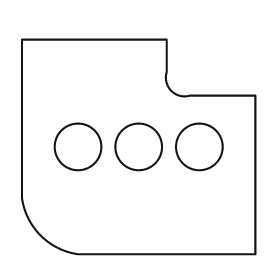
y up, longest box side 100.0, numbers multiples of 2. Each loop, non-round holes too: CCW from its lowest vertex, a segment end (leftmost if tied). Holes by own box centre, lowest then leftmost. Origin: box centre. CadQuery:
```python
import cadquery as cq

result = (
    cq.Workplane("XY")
    .moveTo(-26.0, -46.0)
    .lineTo(50.0, -46.0)
    .lineTo(50.0, 22.0)
    .lineTo(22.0, 22.0)
    .threePointArc((14.0, 24.0), (12.0, 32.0))
    .lineTo(12.0, 46.0)
    .lineTo(-50.0, 46.0)
    .lineTo(-50.0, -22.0)
    .threePointArc((-42.0, -38.0), (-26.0, -46.0))
    .close()
    .moveTo(-26.0, 0.0)
    .circle(10.0)
    .moveTo(0.0, 0.0)
    .circle(10.0)
    .moveTo(26.0, 0.0)
    .circle(10.0)
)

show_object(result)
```